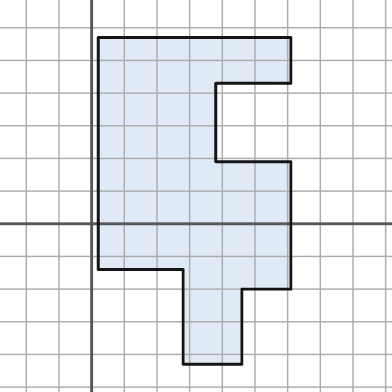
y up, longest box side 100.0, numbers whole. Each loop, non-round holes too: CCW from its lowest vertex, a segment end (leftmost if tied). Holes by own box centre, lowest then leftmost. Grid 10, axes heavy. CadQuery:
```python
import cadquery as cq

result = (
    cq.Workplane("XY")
    .moveTo(28.0, -43.0)
    .lineTo(46.0, -43.0)
    .lineTo(46.0, -20.0)
    .lineTo(61.0, -20.0)
    .lineTo(61.0, 19.0)
    .lineTo(38.0, 19.0)
    .lineTo(38.0, 43.0)
    .lineTo(61.0, 43.0)
    .lineTo(61.0, 57.0)
    .lineTo(2.0, 57.0)
    .lineTo(2.0, -14.0)
    .lineTo(28.0, -14.0)
    .close()
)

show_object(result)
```